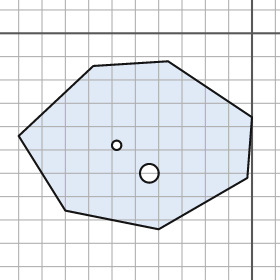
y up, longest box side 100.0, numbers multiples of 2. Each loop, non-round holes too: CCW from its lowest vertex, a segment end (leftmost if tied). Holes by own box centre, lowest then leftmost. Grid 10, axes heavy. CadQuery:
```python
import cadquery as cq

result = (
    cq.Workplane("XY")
    .moveTo(-40.0, -84.0)
    .lineTo(-2.0, -62.0)
    .lineTo(0.0, -36.0)
    .lineTo(-36.0, -12.0)
    .lineTo(-68.0, -14.0)
    .lineTo(-100.0, -44.0)
    .lineTo(-80.0, -76.0)
    .close()
    .moveTo(-44.0, -60.0)
    .circle(4.0)
    .moveTo(-58.0, -48.0)
    .circle(2.0)
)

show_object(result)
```